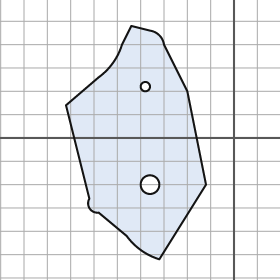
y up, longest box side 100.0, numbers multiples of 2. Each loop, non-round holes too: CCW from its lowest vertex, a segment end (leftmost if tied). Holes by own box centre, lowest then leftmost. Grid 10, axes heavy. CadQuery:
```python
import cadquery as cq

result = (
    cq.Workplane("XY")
    .moveTo(-32.0, -52.0)
    .lineTo(-12.0, -20.0)
    .lineTo(-20.0, 20.0)
    .lineTo(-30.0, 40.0)
    .threePointArc((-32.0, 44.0), (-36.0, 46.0))
    .lineTo(-44.0, 48.0)
    .lineTo(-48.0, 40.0)
    .threePointArc((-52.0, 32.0), (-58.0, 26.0))
    .lineTo(-72.0, 14.0)
    .lineTo(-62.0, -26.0)
    .threePointArc((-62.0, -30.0), (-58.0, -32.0))
    .lineTo(-46.0, -42.0)
    .threePointArc((-40.0, -48.0), (-32.0, -52.0))
    .close()
    .moveTo(-36.0, -20.0)
    .circle(4.0)
    .moveTo(-38.0, 22.0)
    .circle(2.0)
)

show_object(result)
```